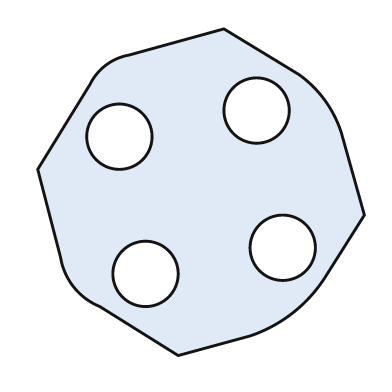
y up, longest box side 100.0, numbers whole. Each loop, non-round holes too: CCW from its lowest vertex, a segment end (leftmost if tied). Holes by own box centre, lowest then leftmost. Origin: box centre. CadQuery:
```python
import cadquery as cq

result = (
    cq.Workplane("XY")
    .moveTo(-7.0, -50.0)
    .lineTo(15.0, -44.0)
    .threePointArc((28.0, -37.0), (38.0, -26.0))
    .lineTo(50.0, -7.0)
    .lineTo(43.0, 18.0)
    .threePointArc((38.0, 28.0), (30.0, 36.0))
    .lineTo(7.0, 50.0)
    .lineTo(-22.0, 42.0)
    .threePointArc((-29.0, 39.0), (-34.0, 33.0))
    .lineTo(-50.0, 7.0)
    .lineTo(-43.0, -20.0)
    .threePointArc((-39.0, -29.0), (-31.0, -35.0))
    .close()
    .moveTo(-17.0, -25.0)
    .circle(10.0)
    .moveTo(25.0, -17.0)
    .circle(10.0)
    .moveTo(-25.0, 17.0)
    .circle(10.0)
    .moveTo(17.0, 25.0)
    .circle(10.0)
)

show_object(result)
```